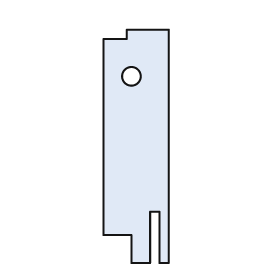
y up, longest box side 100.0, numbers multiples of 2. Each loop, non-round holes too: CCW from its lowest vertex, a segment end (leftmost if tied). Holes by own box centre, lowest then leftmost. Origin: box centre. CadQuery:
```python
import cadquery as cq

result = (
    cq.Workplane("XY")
    .moveTo(-2.0, -50.0)
    .lineTo(6.0, -50.0)
    .lineTo(6.0, -28.0)
    .lineTo(10.0, -28.0)
    .lineTo(10.0, -50.0)
    .lineTo(14.0, -50.0)
    .lineTo(14.0, 50.0)
    .lineTo(-4.0, 50.0)
    .lineTo(-4.0, 46.0)
    .lineTo(-14.0, 46.0)
    .lineTo(-14.0, -38.0)
    .lineTo(-2.0, -38.0)
    .close()
    .moveTo(-2.0, 30.0)
    .circle(4.0)
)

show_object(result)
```